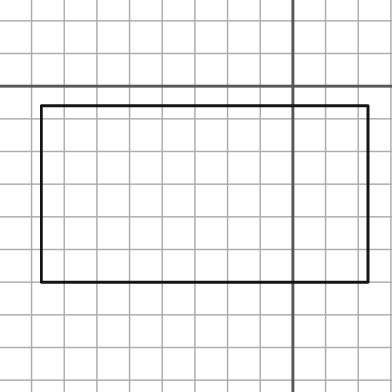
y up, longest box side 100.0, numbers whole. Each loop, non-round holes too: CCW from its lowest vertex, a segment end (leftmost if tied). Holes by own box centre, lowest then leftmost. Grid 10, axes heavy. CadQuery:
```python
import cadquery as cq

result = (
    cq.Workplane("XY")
    .moveTo(-77.0, -60.0)
    .lineTo(23.0, -60.0)
    .lineTo(23.0, -6.0)
    .lineTo(-77.0, -6.0)
    .close()
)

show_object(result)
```